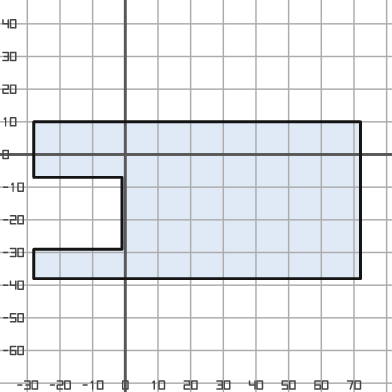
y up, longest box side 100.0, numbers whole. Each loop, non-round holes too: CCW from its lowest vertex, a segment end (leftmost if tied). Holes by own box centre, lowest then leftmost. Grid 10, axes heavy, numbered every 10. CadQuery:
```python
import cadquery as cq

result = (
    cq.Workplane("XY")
    .moveTo(-28.0, -38.0)
    .lineTo(72.0, -38.0)
    .lineTo(72.0, 10.0)
    .lineTo(-28.0, 10.0)
    .lineTo(-28.0, -7.0)
    .lineTo(-1.0, -7.0)
    .lineTo(-1.0, -29.0)
    .lineTo(-28.0, -29.0)
    .close()
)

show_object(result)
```